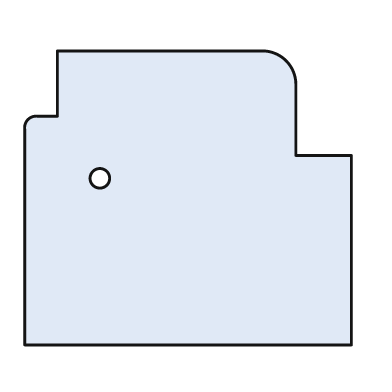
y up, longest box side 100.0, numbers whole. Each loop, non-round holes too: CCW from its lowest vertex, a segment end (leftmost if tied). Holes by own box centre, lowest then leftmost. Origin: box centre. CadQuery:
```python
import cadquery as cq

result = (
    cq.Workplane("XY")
    .moveTo(-50.0, -45.0)
    .lineTo(50.0, -45.0)
    .lineTo(50.0, 13.0)
    .lineTo(33.0, 13.0)
    .lineTo(33.0, 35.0)
    .threePointArc((30.0, 42.0), (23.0, 45.0))
    .lineTo(-40.0, 45.0)
    .lineTo(-40.0, 25.0)
    .lineTo(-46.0, 25.0)
    .threePointArc((-49.0, 24.0), (-50.0, 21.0))
    .close()
    .moveTo(-27.0, 6.0)
    .circle(3.0)
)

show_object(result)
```